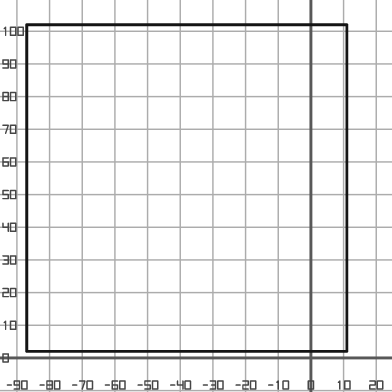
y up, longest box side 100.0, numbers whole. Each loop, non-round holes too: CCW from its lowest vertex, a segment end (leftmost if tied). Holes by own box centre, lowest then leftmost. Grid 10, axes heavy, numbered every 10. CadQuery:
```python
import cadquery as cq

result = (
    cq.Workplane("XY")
    .moveTo(-87.0, 2.0)
    .lineTo(11.0, 2.0)
    .lineTo(11.0, 102.0)
    .lineTo(-87.0, 102.0)
    .close()
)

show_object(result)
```